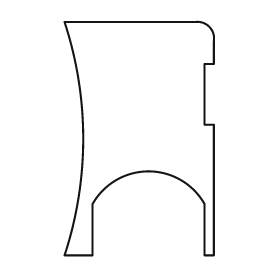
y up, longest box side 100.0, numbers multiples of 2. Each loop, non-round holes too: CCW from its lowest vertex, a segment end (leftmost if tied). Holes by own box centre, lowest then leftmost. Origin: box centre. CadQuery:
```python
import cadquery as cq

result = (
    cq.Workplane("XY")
    .moveTo(-32.0, -50.0)
    .lineTo(-20.0, -50.0)
    .lineTo(-20.0, -28.0)
    .threePointArc((4.0, -14.0), (28.0, -28.0))
    .lineTo(28.0, -50.0)
    .lineTo(32.0, -50.0)
    .lineTo(32.0, 6.0)
    .lineTo(28.0, 6.0)
    .lineTo(28.0, 32.0)
    .lineTo(32.0, 32.0)
    .lineTo(32.0, 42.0)
    .threePointArc((30.0, 48.0), (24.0, 50.0))
    .lineTo(-32.0, 50.0)
    .threePointArc((-24.0, 0.0), (-32.0, -50.0))
    .close()
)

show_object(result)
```